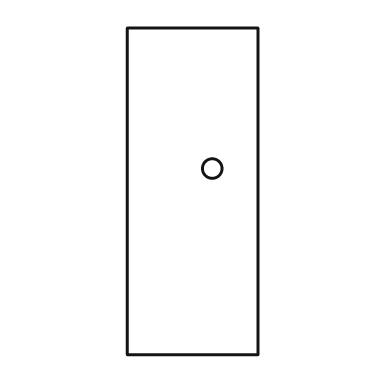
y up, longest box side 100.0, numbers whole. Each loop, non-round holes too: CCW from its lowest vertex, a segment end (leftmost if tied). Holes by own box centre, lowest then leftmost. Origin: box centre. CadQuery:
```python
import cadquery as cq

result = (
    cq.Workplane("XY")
    .moveTo(-20.0, -50.0)
    .lineTo(20.0, -50.0)
    .lineTo(20.0, 50.0)
    .lineTo(-20.0, 50.0)
    .close()
    .moveTo(6.0, 7.0)
    .circle(3.0)
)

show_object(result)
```